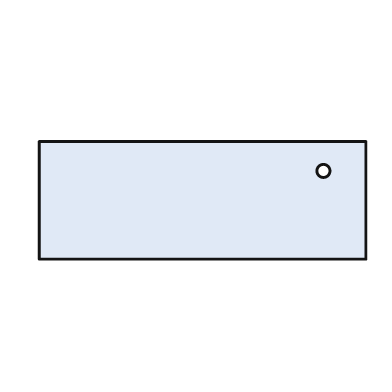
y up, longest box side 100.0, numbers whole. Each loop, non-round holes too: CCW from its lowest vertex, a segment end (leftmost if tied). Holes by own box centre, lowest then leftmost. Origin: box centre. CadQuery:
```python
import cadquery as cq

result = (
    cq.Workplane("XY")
    .moveTo(-50.0, -18.0)
    .lineTo(50.0, -18.0)
    .lineTo(50.0, 18.0)
    .lineTo(-50.0, 18.0)
    .close()
    .moveTo(37.0, 9.0)
    .circle(2.0)
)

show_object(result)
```